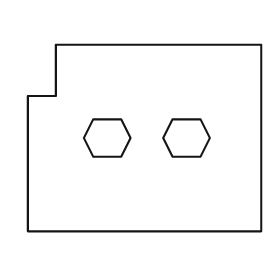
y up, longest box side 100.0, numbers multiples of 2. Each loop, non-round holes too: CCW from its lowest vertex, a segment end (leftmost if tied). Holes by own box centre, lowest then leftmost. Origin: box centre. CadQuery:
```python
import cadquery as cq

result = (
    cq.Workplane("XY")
    .moveTo(-50.0, -40.0)
    .lineTo(50.0, -40.0)
    .lineTo(50.0, 40.0)
    .lineTo(-38.0, 40.0)
    .lineTo(-38.0, 18.0)
    .lineTo(-50.0, 18.0)
    .close()
    .moveTo(-22.0, -8.0)
    .lineTo(-10.0, -8.0)
    .lineTo(-6.0, 0.0)
    .lineTo(-10.0, 8.0)
    .lineTo(-22.0, 8.0)
    .lineTo(-26.0, 0.0)
    .close()
    .moveTo(12.0, -8.0)
    .lineTo(24.0, -8.0)
    .lineTo(28.0, 0.0)
    .lineTo(24.0, 8.0)
    .lineTo(12.0, 8.0)
    .lineTo(8.0, 0.0)
    .close()
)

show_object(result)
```